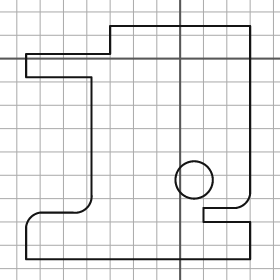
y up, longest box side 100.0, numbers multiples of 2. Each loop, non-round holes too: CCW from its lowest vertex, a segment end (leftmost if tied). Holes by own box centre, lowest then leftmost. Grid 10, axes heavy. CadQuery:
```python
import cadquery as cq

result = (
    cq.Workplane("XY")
    .moveTo(-66.0, -86.0)
    .lineTo(30.0, -86.0)
    .lineTo(30.0, -70.0)
    .lineTo(10.0, -70.0)
    .lineTo(10.0, -64.0)
    .lineTo(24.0, -64.0)
    .threePointArc((28.0, -62.0), (30.0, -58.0))
    .lineTo(30.0, 14.0)
    .lineTo(-30.0, 14.0)
    .lineTo(-30.0, 2.0)
    .lineTo(-66.0, 2.0)
    .lineTo(-66.0, -8.0)
    .lineTo(-38.0, -8.0)
    .lineTo(-38.0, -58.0)
    .threePointArc((-40.0, -64.0), (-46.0, -66.0))
    .lineTo(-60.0, -66.0)
    .threePointArc((-64.0, -68.0), (-66.0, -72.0))
    .close()
    .moveTo(6.0, -52.0)
    .circle(8.0)
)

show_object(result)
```